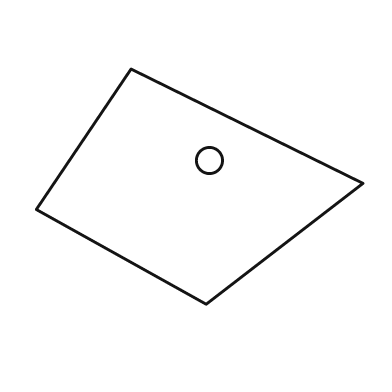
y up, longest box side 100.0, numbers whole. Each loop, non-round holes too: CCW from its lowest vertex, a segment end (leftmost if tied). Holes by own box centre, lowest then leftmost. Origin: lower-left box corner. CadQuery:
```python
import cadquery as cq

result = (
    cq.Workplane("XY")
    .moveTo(52.0, 0.0)
    .lineTo(100.0, 37.0)
    .lineTo(29.0, 72.0)
    .lineTo(0.0, 29.0)
    .close()
    .moveTo(53.0, 44.0)
    .circle(4.0)
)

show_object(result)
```